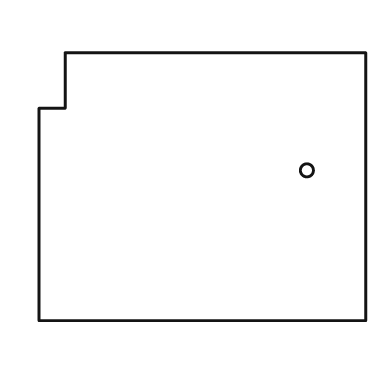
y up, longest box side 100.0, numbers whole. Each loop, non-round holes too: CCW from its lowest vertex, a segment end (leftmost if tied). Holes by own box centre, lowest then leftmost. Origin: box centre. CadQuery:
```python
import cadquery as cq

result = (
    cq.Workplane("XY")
    .moveTo(-50.0, -41.0)
    .lineTo(50.0, -41.0)
    .lineTo(50.0, 41.0)
    .lineTo(-42.0, 41.0)
    .lineTo(-42.0, 24.0)
    .lineTo(-50.0, 24.0)
    .close()
    .moveTo(32.0, 5.0)
    .circle(2.0)
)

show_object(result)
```